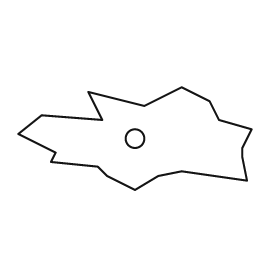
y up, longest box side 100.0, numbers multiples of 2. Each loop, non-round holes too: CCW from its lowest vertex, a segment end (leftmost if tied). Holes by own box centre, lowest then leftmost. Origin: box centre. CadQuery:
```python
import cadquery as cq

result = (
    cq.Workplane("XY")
    .moveTo(0.0, -22.0)
    .lineTo(10.0, -16.0)
    .lineTo(20.0, -14.0)
    .lineTo(48.0, -18.0)
    .lineTo(46.0, -8.0)
    .lineTo(46.0, -4.0)
    .lineTo(50.0, 4.0)
    .lineTo(36.0, 8.0)
    .lineTo(32.0, 16.0)
    .lineTo(20.0, 22.0)
    .lineTo(4.0, 14.0)
    .lineTo(-20.0, 20.0)
    .lineTo(-14.0, 8.0)
    .lineTo(-40.0, 10.0)
    .lineTo(-50.0, 2.0)
    .lineTo(-34.0, -6.0)
    .lineTo(-36.0, -10.0)
    .lineTo(-16.0, -12.0)
    .lineTo(-12.0, -16.0)
    .close()
    .moveTo(0.0, 0.0)
    .circle(4.0)
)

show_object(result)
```